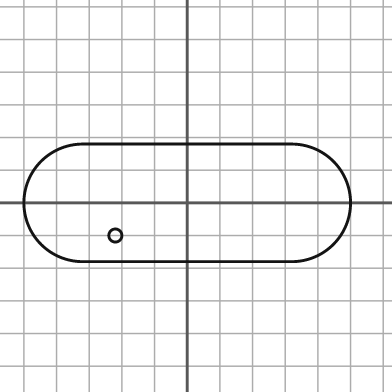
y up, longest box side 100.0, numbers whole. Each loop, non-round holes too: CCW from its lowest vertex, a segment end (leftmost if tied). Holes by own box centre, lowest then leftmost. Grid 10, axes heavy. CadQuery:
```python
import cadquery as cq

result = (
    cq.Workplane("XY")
    .moveTo(-32.0, -18.0)
    .lineTo(32.0, -18.0)
    .threePointArc((50.0, 0.0), (32.0, 18.0))
    .lineTo(-32.0, 18.0)
    .threePointArc((-50.0, 0.0), (-32.0, -18.0))
    .close()
    .moveTo(-22.0, -10.0)
    .circle(2.0)
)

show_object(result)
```